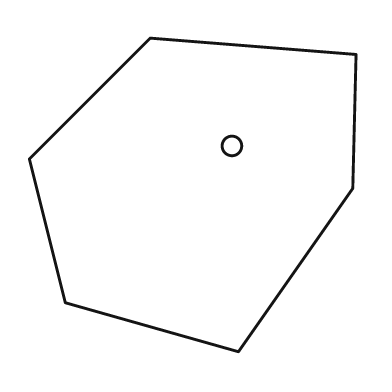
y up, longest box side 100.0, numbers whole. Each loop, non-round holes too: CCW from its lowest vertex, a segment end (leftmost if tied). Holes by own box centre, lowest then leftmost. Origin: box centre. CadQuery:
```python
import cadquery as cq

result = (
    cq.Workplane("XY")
    .moveTo(14.0, -48.0)
    .lineTo(49.0, 2.0)
    .lineTo(50.0, 43.0)
    .lineTo(-13.0, 48.0)
    .lineTo(-50.0, 11.0)
    .lineTo(-39.0, -33.0)
    .close()
    .moveTo(12.0, 15.0)
    .circle(3.0)
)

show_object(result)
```